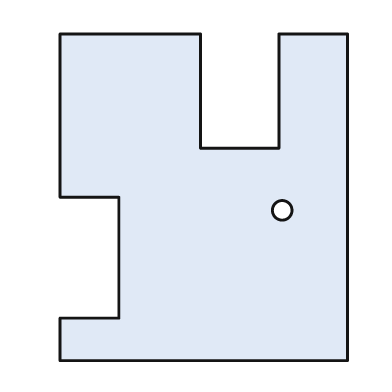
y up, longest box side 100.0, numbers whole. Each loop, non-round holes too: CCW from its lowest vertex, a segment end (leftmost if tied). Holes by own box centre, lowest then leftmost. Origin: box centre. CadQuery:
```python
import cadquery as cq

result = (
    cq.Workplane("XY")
    .moveTo(-44.0, -50.0)
    .lineTo(44.0, -50.0)
    .lineTo(44.0, 50.0)
    .lineTo(23.0, 50.0)
    .lineTo(23.0, 15.0)
    .lineTo(-1.0, 15.0)
    .lineTo(-1.0, 50.0)
    .lineTo(-44.0, 50.0)
    .lineTo(-44.0, 0.0)
    .lineTo(-26.0, 0.0)
    .lineTo(-26.0, -37.0)
    .lineTo(-44.0, -37.0)
    .close()
    .moveTo(24.0, -4.0)
    .circle(3.0)
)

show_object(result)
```